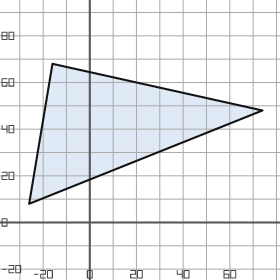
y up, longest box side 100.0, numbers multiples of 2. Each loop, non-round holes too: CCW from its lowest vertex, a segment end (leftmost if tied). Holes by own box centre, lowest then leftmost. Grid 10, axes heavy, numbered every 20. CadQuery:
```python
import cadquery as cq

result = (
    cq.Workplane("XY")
    .moveTo(-26.0, 8.0)
    .lineTo(74.0, 48.0)
    .lineTo(-16.0, 68.0)
    .close()
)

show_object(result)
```